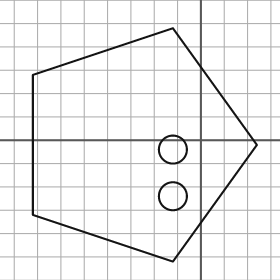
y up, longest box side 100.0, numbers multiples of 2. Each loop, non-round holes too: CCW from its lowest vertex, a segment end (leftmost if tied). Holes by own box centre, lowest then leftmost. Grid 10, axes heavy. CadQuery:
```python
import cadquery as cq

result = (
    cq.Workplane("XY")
    .moveTo(-12.0, -52.0)
    .lineTo(24.0, -2.0)
    .lineTo(-12.0, 48.0)
    .lineTo(-72.0, 28.0)
    .lineTo(-72.0, -32.0)
    .close()
    .moveTo(-12.0, -24.0)
    .circle(6.0)
    .moveTo(-12.0, -4.0)
    .circle(6.0)
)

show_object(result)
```